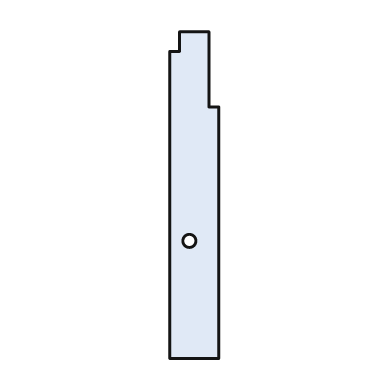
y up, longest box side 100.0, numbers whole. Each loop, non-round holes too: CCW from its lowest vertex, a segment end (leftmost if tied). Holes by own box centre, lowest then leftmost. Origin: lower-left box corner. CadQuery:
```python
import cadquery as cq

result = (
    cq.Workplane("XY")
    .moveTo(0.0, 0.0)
    .lineTo(15.0, 0.0)
    .lineTo(15.0, 77.0)
    .lineTo(12.0, 77.0)
    .lineTo(12.0, 100.0)
    .lineTo(3.0, 100.0)
    .lineTo(3.0, 94.0)
    .lineTo(0.0, 94.0)
    .close()
    .moveTo(6.0, 36.0)
    .circle(2.0)
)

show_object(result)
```